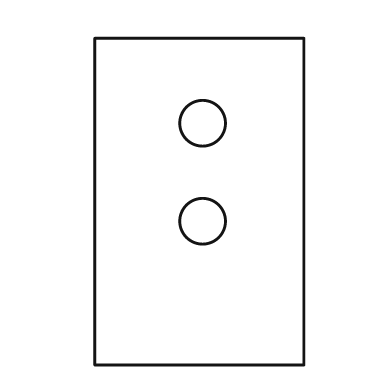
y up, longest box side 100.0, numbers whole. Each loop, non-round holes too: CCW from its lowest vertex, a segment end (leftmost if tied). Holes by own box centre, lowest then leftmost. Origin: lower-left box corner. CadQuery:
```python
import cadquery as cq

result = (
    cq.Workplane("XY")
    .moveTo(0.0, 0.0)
    .lineTo(64.0, 0.0)
    .lineTo(64.0, 100.0)
    .lineTo(0.0, 100.0)
    .close()
    .moveTo(33.0, 44.0)
    .circle(7.0)
    .moveTo(33.0, 74.0)
    .circle(7.0)
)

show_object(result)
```